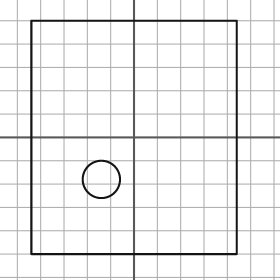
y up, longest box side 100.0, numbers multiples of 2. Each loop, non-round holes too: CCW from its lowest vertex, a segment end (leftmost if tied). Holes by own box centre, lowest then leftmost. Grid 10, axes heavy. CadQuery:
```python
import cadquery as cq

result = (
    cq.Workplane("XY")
    .moveTo(-44.0, -50.0)
    .lineTo(44.0, -50.0)
    .lineTo(44.0, 50.0)
    .lineTo(-44.0, 50.0)
    .close()
    .moveTo(-14.0, -18.0)
    .circle(8.0)
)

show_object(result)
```